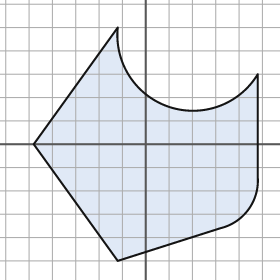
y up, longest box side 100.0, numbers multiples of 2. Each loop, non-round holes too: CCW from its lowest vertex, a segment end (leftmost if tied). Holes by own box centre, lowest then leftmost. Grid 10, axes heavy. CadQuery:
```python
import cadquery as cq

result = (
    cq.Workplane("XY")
    .moveTo(-12.0, -50.0)
    .lineTo(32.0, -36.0)
    .threePointArc((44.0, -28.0), (48.0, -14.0))
    .lineTo(48.0, 30.0)
    .threePointArc((10.0, 16.0), (-12.0, 50.0))
    .lineTo(-48.0, 0.0)
    .close()
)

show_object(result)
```